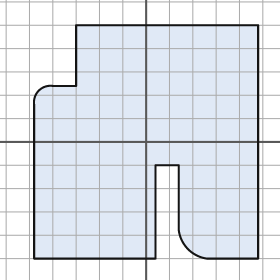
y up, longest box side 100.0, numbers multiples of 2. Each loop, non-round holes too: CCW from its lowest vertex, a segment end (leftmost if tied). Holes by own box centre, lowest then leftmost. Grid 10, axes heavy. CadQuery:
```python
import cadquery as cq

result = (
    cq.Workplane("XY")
    .moveTo(-48.0, -50.0)
    .lineTo(4.0, -50.0)
    .lineTo(4.0, -10.0)
    .lineTo(14.0, -10.0)
    .lineTo(14.0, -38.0)
    .threePointArc((18.0, -46.0), (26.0, -50.0))
    .lineTo(48.0, -50.0)
    .lineTo(48.0, 50.0)
    .lineTo(-30.0, 50.0)
    .lineTo(-30.0, 24.0)
    .lineTo(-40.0, 24.0)
    .threePointArc((-46.0, 22.0), (-48.0, 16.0))
    .close()
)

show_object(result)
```